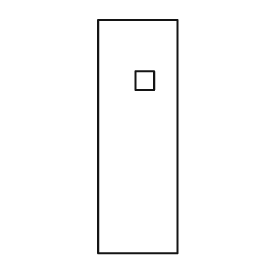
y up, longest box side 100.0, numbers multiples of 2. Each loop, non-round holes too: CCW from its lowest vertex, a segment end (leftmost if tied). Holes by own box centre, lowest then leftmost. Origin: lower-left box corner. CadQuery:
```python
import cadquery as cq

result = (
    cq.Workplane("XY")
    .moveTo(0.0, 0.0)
    .lineTo(34.0, 0.0)
    .lineTo(34.0, 100.0)
    .lineTo(0.0, 100.0)
    .close()
    .moveTo(16.0, 70.0)
    .lineTo(24.0, 70.0)
    .lineTo(24.0, 78.0)
    .lineTo(16.0, 78.0)
    .close()
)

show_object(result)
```